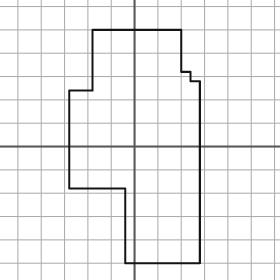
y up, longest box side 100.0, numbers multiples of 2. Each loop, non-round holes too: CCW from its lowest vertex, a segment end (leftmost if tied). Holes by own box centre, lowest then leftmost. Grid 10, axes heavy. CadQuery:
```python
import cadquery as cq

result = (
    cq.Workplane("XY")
    .moveTo(-4.0, -50.0)
    .lineTo(28.0, -50.0)
    .lineTo(28.0, 28.0)
    .lineTo(24.0, 28.0)
    .lineTo(24.0, 32.0)
    .lineTo(20.0, 32.0)
    .lineTo(20.0, 50.0)
    .lineTo(-18.0, 50.0)
    .lineTo(-18.0, 24.0)
    .lineTo(-28.0, 24.0)
    .lineTo(-28.0, -18.0)
    .lineTo(-4.0, -18.0)
    .close()
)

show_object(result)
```